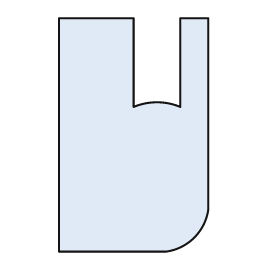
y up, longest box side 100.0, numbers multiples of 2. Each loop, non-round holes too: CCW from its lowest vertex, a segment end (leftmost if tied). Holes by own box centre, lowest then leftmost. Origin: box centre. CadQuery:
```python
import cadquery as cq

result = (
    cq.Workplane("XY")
    .moveTo(-32.0, -50.0)
    .lineTo(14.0, -50.0)
    .threePointArc((26.0, -44.0), (32.0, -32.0))
    .lineTo(32.0, 50.0)
    .lineTo(20.0, 50.0)
    .lineTo(20.0, 12.0)
    .threePointArc((10.0, 14.0), (0.0, 12.0))
    .lineTo(0.0, 50.0)
    .lineTo(-32.0, 50.0)
    .close()
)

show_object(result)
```